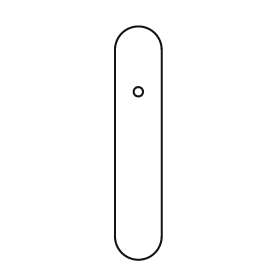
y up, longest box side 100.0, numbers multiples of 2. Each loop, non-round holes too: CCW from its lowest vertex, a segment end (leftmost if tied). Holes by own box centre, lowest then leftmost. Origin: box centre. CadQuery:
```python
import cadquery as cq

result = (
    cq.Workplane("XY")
    .moveTo(-10.0, -40.0)
    .threePointArc((0.0, -50.0), (10.0, -40.0))
    .lineTo(10.0, 40.0)
    .threePointArc((0.0, 50.0), (-10.0, 40.0))
    .close()
    .moveTo(0.0, 22.0)
    .circle(2.0)
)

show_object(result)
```